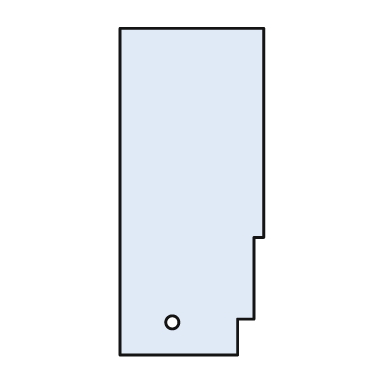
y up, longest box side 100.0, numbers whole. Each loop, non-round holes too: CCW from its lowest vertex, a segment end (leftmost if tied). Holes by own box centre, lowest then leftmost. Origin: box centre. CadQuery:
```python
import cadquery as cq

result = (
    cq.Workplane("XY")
    .moveTo(-22.0, -50.0)
    .lineTo(14.0, -50.0)
    .lineTo(14.0, -39.0)
    .lineTo(19.0, -39.0)
    .lineTo(19.0, -14.0)
    .lineTo(22.0, -14.0)
    .lineTo(22.0, 50.0)
    .lineTo(-22.0, 50.0)
    .close()
    .moveTo(-6.0, -40.0)
    .circle(2.0)
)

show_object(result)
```